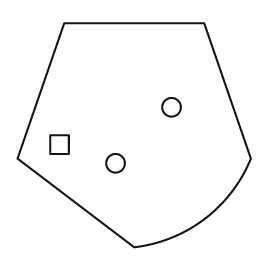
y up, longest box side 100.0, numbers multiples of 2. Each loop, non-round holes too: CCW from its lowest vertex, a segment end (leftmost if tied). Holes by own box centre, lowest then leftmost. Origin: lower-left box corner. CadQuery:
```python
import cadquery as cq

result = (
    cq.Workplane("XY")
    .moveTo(50.0, 0.0)
    .threePointArc((80.0, 12.0), (100.0, 38.0))
    .lineTo(80.0, 96.0)
    .lineTo(20.0, 96.0)
    .lineTo(0.0, 38.0)
    .close()
    .moveTo(42.0, 36.0)
    .circle(4.0)
    .moveTo(14.0, 40.0)
    .lineTo(22.0, 40.0)
    .lineTo(22.0, 48.0)
    .lineTo(14.0, 48.0)
    .close()
    .moveTo(66.0, 60.0)
    .circle(4.0)
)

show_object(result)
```